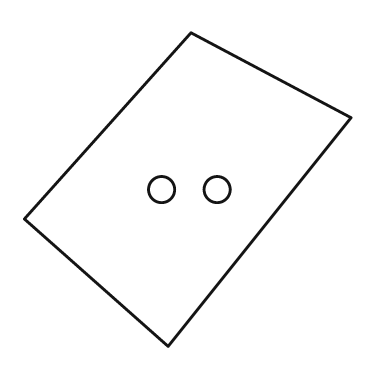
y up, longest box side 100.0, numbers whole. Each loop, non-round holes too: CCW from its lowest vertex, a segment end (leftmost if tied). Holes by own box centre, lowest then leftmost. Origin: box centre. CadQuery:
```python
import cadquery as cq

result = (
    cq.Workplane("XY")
    .moveTo(-6.0, -48.0)
    .lineTo(50.0, 22.0)
    .lineTo(1.0, 48.0)
    .lineTo(-50.0, -9.0)
    .close()
    .moveTo(-8.0, 0.0)
    .circle(4.0)
    .moveTo(9.0, 0.0)
    .circle(4.0)
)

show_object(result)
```